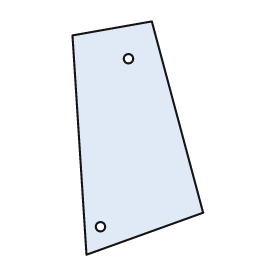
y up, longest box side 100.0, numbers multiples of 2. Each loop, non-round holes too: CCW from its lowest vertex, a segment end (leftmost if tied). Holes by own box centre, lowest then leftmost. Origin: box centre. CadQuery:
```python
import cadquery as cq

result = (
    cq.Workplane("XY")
    .moveTo(-22.0, -50.0)
    .lineTo(28.0, -32.0)
    .lineTo(6.0, 50.0)
    .lineTo(-28.0, 44.0)
    .close()
    .moveTo(-16.0, -38.0)
    .circle(2.0)
    .moveTo(-4.0, 34.0)
    .circle(2.0)
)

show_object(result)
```